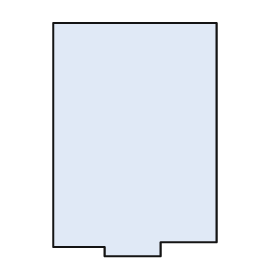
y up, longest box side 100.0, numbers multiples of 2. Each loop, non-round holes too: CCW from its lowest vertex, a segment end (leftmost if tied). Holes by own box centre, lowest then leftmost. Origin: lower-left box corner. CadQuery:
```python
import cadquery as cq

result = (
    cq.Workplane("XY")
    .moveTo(22.0, 0.0)
    .lineTo(46.0, 0.0)
    .lineTo(46.0, 6.0)
    .lineTo(70.0, 6.0)
    .lineTo(70.0, 100.0)
    .lineTo(0.0, 100.0)
    .lineTo(0.0, 4.0)
    .lineTo(22.0, 4.0)
    .close()
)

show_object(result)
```